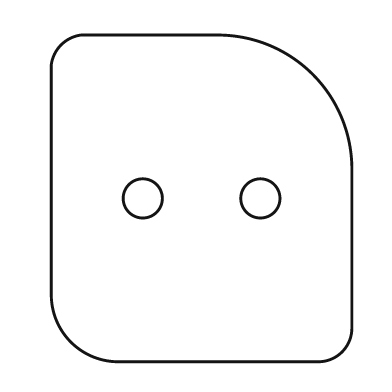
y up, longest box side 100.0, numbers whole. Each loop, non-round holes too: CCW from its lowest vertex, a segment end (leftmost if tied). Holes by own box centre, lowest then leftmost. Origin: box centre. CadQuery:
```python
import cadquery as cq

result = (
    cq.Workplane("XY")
    .moveTo(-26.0, -50.0)
    .lineTo(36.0, -50.0)
    .threePointArc((43.0, -47.0), (46.0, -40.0))
    .lineTo(46.0, 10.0)
    .threePointArc((34.0, 38.0), (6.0, 50.0))
    .lineTo(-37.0, 50.0)
    .threePointArc((-43.0, 47.0), (-46.0, 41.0))
    .lineTo(-46.0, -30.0)
    .threePointArc((-40.0, -44.0), (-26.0, -50.0))
    .close()
    .moveTo(-18.0, 0.0)
    .circle(6.0)
    .moveTo(18.0, 0.0)
    .circle(6.0)
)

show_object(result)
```